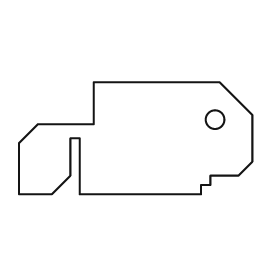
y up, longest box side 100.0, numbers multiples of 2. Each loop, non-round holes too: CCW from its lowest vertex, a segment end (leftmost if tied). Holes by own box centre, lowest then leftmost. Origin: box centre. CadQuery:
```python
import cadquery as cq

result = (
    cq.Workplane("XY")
    .moveTo(-50.0, -24.0)
    .lineTo(-36.0, -24.0)
    .lineTo(-28.0, -16.0)
    .lineTo(-28.0, 0.0)
    .lineTo(-24.0, 0.0)
    .lineTo(-24.0, -24.0)
    .lineTo(28.0, -24.0)
    .lineTo(28.0, -20.0)
    .lineTo(32.0, -20.0)
    .lineTo(32.0, -16.0)
    .lineTo(44.0, -16.0)
    .lineTo(50.0, -10.0)
    .lineTo(50.0, 10.0)
    .lineTo(36.0, 24.0)
    .lineTo(-18.0, 24.0)
    .lineTo(-18.0, 6.0)
    .lineTo(-42.0, 6.0)
    .lineTo(-50.0, -2.0)
    .close()
    .moveTo(34.0, 8.0)
    .circle(4.0)
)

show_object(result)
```